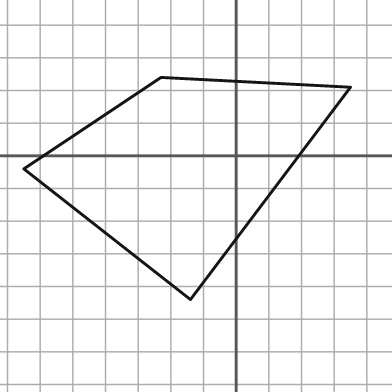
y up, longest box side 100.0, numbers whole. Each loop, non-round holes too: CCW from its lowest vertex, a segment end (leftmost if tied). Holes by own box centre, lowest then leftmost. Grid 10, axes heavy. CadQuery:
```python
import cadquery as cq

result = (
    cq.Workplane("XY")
    .moveTo(-14.0, -44.0)
    .lineTo(35.0, 21.0)
    .lineTo(-23.0, 24.0)
    .lineTo(-65.0, -4.0)
    .close()
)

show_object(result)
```